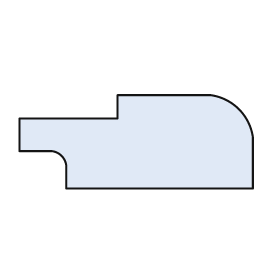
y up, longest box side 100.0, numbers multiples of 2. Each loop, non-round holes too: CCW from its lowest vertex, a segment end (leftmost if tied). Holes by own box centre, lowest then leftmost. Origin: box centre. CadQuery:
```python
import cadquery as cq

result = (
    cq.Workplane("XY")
    .moveTo(-30.0, -20.0)
    .lineTo(50.0, -20.0)
    .lineTo(50.0, 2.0)
    .threePointArc((44.0, 14.0), (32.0, 20.0))
    .lineTo(-8.0, 20.0)
    .lineTo(-8.0, 10.0)
    .lineTo(-50.0, 10.0)
    .lineTo(-50.0, -4.0)
    .lineTo(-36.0, -4.0)
    .threePointArc((-32.0, -6.0), (-30.0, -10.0))
    .close()
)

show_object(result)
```